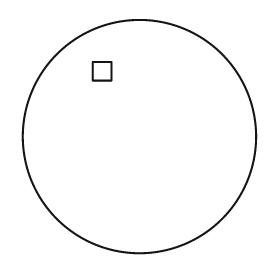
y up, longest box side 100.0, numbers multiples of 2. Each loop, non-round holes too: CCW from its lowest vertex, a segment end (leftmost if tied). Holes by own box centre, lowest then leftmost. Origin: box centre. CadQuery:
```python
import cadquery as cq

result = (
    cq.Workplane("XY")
    .moveTo(0.0, 0.0)
    .circle(50.0)
    .moveTo(-20.0, 24.0)
    .lineTo(-12.0, 24.0)
    .lineTo(-12.0, 32.0)
    .lineTo(-20.0, 32.0)
    .close()
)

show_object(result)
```